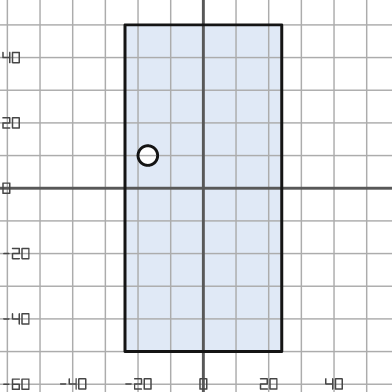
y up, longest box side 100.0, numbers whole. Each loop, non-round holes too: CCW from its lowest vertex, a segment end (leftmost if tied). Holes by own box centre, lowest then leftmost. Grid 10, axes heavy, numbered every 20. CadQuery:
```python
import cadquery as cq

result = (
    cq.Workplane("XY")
    .moveTo(-24.0, -50.0)
    .lineTo(24.0, -50.0)
    .lineTo(24.0, 50.0)
    .lineTo(-24.0, 50.0)
    .close()
    .moveTo(-17.0, 10.0)
    .circle(3.0)
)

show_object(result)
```